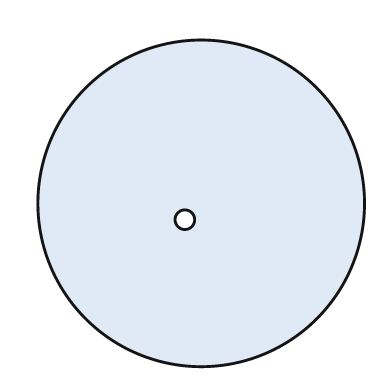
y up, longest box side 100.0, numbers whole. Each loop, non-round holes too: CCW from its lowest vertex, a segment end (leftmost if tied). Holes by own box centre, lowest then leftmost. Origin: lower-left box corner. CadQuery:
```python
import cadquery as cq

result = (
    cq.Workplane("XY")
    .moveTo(50.0, 50.0)
    .circle(50.0)
    .moveTo(45.0, 45.0)
    .circle(3.0)
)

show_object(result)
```